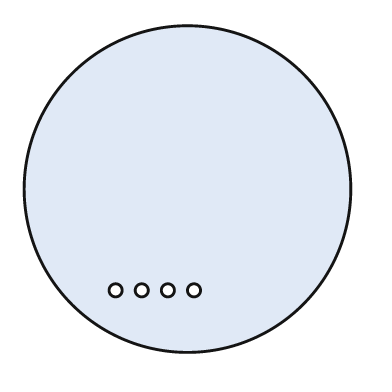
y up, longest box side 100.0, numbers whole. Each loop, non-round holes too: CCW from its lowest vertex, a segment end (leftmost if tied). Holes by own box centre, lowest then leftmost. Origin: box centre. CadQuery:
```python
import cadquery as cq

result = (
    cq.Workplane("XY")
    .moveTo(0.0, 0.0)
    .circle(50.0)
    .moveTo(-22.0, -31.0)
    .circle(2.0)
    .moveTo(-14.0, -31.0)
    .circle(2.0)
    .moveTo(-6.0, -31.0)
    .circle(2.0)
    .moveTo(2.0, -31.0)
    .circle(2.0)
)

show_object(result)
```